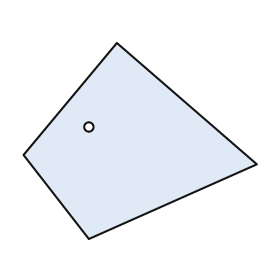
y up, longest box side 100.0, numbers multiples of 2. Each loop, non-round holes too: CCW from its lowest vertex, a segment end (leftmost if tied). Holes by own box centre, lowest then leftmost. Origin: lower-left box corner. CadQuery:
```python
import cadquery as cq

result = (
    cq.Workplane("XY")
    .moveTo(28.0, 0.0)
    .lineTo(100.0, 32.0)
    .lineTo(40.0, 84.0)
    .lineTo(0.0, 36.0)
    .close()
    .moveTo(28.0, 48.0)
    .circle(2.0)
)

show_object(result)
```